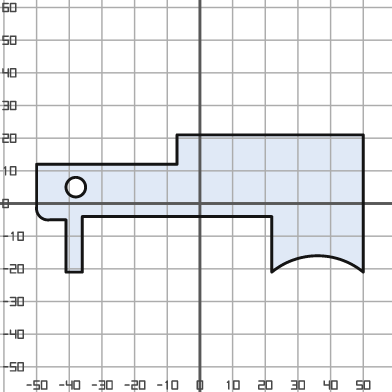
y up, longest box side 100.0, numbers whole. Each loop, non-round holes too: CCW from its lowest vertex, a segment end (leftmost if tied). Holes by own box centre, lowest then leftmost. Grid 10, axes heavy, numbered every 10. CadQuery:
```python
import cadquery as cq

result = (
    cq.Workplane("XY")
    .moveTo(-41.0, -21.0)
    .lineTo(-36.0, -21.0)
    .lineTo(-36.0, -4.0)
    .lineTo(22.0, -4.0)
    .lineTo(22.0, -21.0)
    .threePointArc((36.0, -16.0), (50.0, -21.0))
    .lineTo(50.0, 21.0)
    .lineTo(-7.0, 21.0)
    .lineTo(-7.0, 12.0)
    .lineTo(-50.0, 12.0)
    .lineTo(-50.0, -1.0)
    .threePointArc((-49.0, -4.0), (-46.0, -5.0))
    .lineTo(-41.0, -5.0)
    .close()
    .moveTo(-38.0, 5.0)
    .circle(3.0)
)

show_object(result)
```